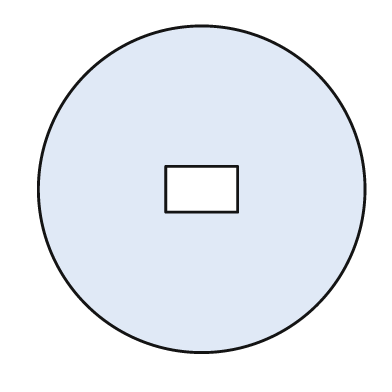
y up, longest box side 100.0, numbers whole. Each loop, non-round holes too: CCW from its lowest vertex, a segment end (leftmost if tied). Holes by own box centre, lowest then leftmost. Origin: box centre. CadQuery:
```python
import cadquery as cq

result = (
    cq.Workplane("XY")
    .moveTo(0.0, 0.0)
    .circle(50.0)
    .moveTo(-11.0, -7.0)
    .lineTo(11.0, -7.0)
    .lineTo(11.0, 7.0)
    .lineTo(-11.0, 7.0)
    .close()
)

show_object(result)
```